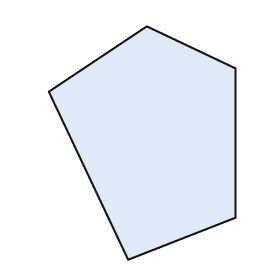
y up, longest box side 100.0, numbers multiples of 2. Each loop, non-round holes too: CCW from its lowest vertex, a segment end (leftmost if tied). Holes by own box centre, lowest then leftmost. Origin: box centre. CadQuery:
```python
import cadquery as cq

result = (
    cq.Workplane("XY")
    .moveTo(-6.0, -50.0)
    .lineTo(40.0, -32.0)
    .lineTo(40.0, 32.0)
    .lineTo(2.0, 50.0)
    .lineTo(-40.0, 22.0)
    .close()
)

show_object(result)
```